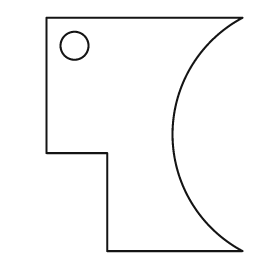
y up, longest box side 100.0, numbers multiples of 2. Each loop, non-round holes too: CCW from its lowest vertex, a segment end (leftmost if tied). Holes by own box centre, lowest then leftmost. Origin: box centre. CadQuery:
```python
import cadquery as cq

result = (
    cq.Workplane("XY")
    .moveTo(-16.0, -50.0)
    .lineTo(42.0, -50.0)
    .threePointArc((12.0, 0.0), (42.0, 50.0))
    .lineTo(-42.0, 50.0)
    .lineTo(-42.0, -8.0)
    .lineTo(-16.0, -8.0)
    .close()
    .moveTo(-30.0, 38.0)
    .circle(6.0)
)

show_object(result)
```